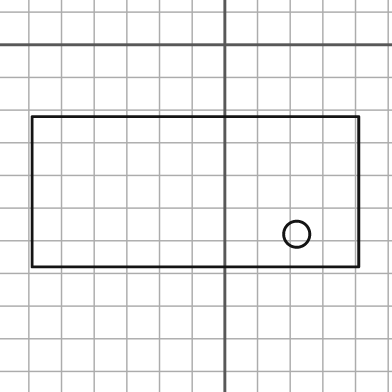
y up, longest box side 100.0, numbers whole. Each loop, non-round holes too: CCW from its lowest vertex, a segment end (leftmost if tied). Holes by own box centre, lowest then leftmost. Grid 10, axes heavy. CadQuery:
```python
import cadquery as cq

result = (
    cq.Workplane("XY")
    .moveTo(-59.0, -68.0)
    .lineTo(41.0, -68.0)
    .lineTo(41.0, -22.0)
    .lineTo(-59.0, -22.0)
    .close()
    .moveTo(22.0, -58.0)
    .circle(4.0)
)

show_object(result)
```